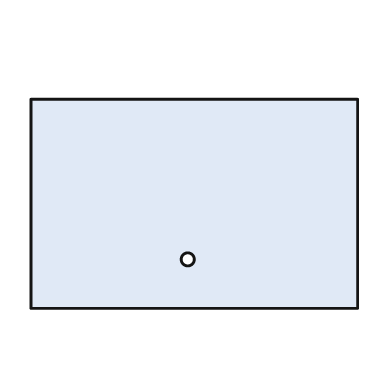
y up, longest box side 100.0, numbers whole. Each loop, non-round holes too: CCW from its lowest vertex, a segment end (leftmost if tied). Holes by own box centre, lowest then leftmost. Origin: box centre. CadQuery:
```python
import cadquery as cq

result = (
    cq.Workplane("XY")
    .moveTo(-50.0, -32.0)
    .lineTo(50.0, -32.0)
    .lineTo(50.0, 32.0)
    .lineTo(-50.0, 32.0)
    .close()
    .moveTo(-2.0, -17.0)
    .circle(2.0)
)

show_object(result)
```